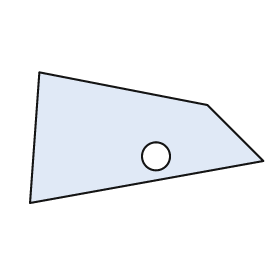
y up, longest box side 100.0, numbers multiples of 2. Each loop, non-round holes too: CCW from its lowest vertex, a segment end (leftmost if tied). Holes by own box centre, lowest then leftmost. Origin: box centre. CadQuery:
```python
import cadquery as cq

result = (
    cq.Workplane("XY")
    .moveTo(-50.0, -28.0)
    .lineTo(50.0, -10.0)
    .lineTo(26.0, 14.0)
    .lineTo(-46.0, 28.0)
    .close()
    .moveTo(4.0, -8.0)
    .circle(6.0)
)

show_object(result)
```